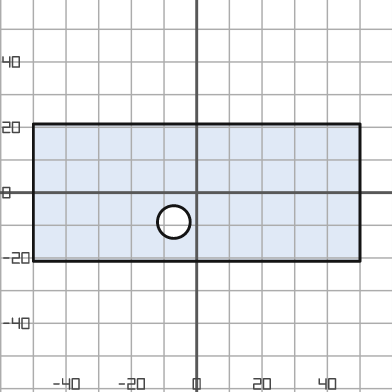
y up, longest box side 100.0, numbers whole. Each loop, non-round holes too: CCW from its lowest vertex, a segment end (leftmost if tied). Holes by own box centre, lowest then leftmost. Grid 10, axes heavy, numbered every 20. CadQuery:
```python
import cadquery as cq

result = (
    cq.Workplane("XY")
    .moveTo(-50.0, -21.0)
    .lineTo(50.0, -21.0)
    .lineTo(50.0, 21.0)
    .lineTo(-50.0, 21.0)
    .close()
    .moveTo(-7.0, -9.0)
    .circle(5.0)
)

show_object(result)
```